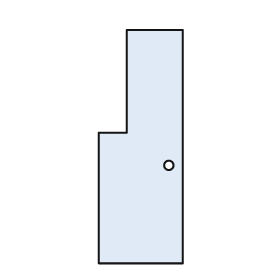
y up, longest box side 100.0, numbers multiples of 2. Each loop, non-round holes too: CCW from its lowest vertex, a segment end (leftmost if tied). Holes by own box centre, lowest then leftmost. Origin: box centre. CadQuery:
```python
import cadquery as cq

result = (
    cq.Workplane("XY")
    .moveTo(-18.0, -50.0)
    .lineTo(18.0, -50.0)
    .lineTo(18.0, 50.0)
    .lineTo(-6.0, 50.0)
    .lineTo(-6.0, 6.0)
    .lineTo(-18.0, 6.0)
    .close()
    .moveTo(12.0, -8.0)
    .circle(2.0)
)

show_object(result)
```